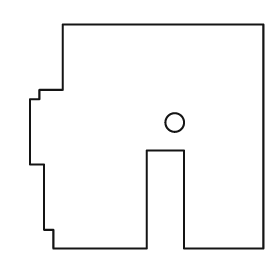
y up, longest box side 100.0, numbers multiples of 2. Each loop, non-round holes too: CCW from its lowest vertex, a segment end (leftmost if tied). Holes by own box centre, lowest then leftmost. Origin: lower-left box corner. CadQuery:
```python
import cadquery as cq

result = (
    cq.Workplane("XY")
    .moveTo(10.0, 0.0)
    .lineTo(50.0, 0.0)
    .lineTo(50.0, 42.0)
    .lineTo(66.0, 42.0)
    .lineTo(66.0, 0.0)
    .lineTo(100.0, 0.0)
    .lineTo(100.0, 96.0)
    .lineTo(14.0, 96.0)
    .lineTo(14.0, 68.0)
    .lineTo(4.0, 68.0)
    .lineTo(4.0, 64.0)
    .lineTo(0.0, 64.0)
    .lineTo(0.0, 36.0)
    .lineTo(6.0, 36.0)
    .lineTo(6.0, 8.0)
    .lineTo(10.0, 8.0)
    .close()
    .moveTo(62.0, 54.0)
    .circle(4.0)
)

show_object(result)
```